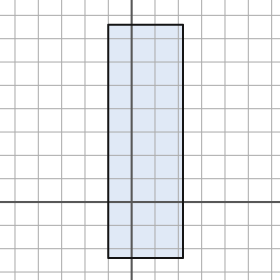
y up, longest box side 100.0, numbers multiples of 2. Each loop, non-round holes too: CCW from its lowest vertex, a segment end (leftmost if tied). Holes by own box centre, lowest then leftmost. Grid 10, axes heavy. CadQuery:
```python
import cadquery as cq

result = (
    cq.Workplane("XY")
    .moveTo(-10.0, -24.0)
    .lineTo(22.0, -24.0)
    .lineTo(22.0, 76.0)
    .lineTo(-10.0, 76.0)
    .close()
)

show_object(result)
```